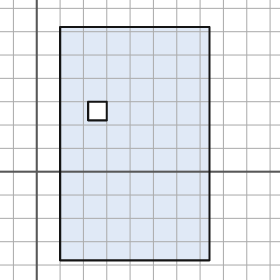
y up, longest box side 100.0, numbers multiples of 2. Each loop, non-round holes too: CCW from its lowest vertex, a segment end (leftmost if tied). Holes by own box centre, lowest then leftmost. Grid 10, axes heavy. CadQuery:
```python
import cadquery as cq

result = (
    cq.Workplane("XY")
    .moveTo(10.0, -38.0)
    .lineTo(74.0, -38.0)
    .lineTo(74.0, 62.0)
    .lineTo(10.0, 62.0)
    .close()
    .moveTo(22.0, 22.0)
    .lineTo(30.0, 22.0)
    .lineTo(30.0, 30.0)
    .lineTo(22.0, 30.0)
    .close()
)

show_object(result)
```